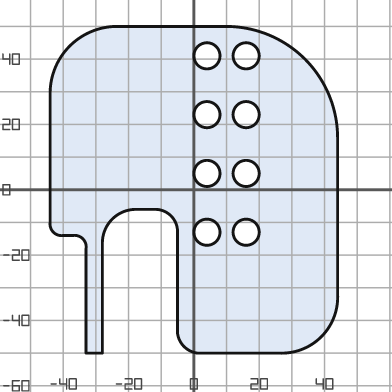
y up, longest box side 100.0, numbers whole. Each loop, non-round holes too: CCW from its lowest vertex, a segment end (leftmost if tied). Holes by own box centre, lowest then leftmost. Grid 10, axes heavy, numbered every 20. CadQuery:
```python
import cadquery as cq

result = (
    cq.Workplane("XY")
    .moveTo(-33.0, -50.0)
    .lineTo(-28.0, -50.0)
    .lineTo(-28.0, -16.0)
    .threePointArc((-25.0, -9.0), (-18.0, -6.0))
    .lineTo(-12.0, -6.0)
    .threePointArc((-7.0, -8.0), (-5.0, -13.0))
    .lineTo(-5.0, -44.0)
    .threePointArc((-3.0, -48.0), (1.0, -50.0))
    .lineTo(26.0, -50.0)
    .threePointArc((39.0, -45.0), (44.0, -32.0))
    .lineTo(44.0, 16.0)
    .threePointArc((34.0, 40.0), (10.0, 50.0))
    .lineTo(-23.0, 50.0)
    .threePointArc((-38.0, 44.0), (-44.0, 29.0))
    .lineTo(-44.0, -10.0)
    .threePointArc((-43.0, -13.0), (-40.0, -14.0))
    .lineTo(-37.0, -14.0)
    .threePointArc((-34.0, -15.0), (-33.0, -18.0))
    .close()
    .moveTo(4.0, -13.0)
    .circle(4.0)
    .moveTo(16.0, -13.0)
    .circle(4.0)
    .moveTo(4.0, 5.0)
    .circle(4.0)
    .moveTo(16.0, 5.0)
    .circle(4.0)
    .moveTo(4.0, 23.0)
    .circle(4.0)
    .moveTo(16.0, 23.0)
    .circle(4.0)
    .moveTo(4.0, 41.0)
    .circle(4.0)
    .moveTo(16.0, 41.0)
    .circle(4.0)
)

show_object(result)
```